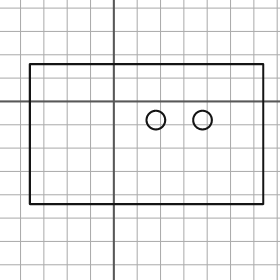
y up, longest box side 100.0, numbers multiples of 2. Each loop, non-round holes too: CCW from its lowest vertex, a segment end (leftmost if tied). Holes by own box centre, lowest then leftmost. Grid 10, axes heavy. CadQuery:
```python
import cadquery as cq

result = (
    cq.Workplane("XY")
    .moveTo(-36.0, -44.0)
    .lineTo(64.0, -44.0)
    .lineTo(64.0, 16.0)
    .lineTo(-36.0, 16.0)
    .close()
    .moveTo(18.0, -8.0)
    .circle(4.0)
    .moveTo(38.0, -8.0)
    .circle(4.0)
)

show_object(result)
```